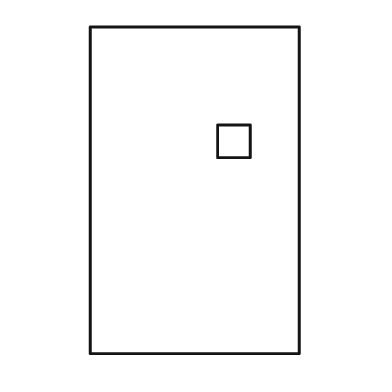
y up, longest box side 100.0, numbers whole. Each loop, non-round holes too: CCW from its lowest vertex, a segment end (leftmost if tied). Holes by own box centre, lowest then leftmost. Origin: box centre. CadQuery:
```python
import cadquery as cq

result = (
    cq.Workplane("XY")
    .moveTo(-32.0, -50.0)
    .lineTo(32.0, -50.0)
    .lineTo(32.0, 50.0)
    .lineTo(-32.0, 50.0)
    .close()
    .moveTo(7.0, 10.0)
    .lineTo(17.0, 10.0)
    .lineTo(17.0, 20.0)
    .lineTo(7.0, 20.0)
    .close()
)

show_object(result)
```